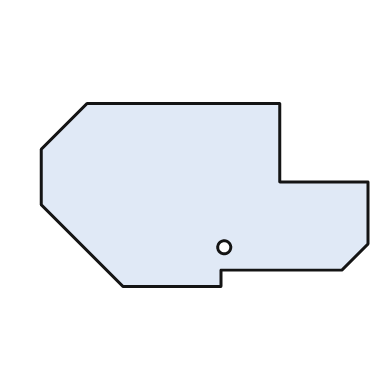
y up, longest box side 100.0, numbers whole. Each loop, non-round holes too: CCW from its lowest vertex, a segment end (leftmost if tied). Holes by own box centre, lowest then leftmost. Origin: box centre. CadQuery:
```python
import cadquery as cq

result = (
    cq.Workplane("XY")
    .moveTo(-25.0, -28.0)
    .lineTo(5.0, -28.0)
    .lineTo(5.0, -23.0)
    .lineTo(42.0, -23.0)
    .lineTo(50.0, -15.0)
    .lineTo(50.0, 4.0)
    .lineTo(23.0, 4.0)
    .lineTo(23.0, 28.0)
    .lineTo(-36.0, 28.0)
    .lineTo(-50.0, 14.0)
    .lineTo(-50.0, -3.0)
    .close()
    .moveTo(6.0, -16.0)
    .circle(2.0)
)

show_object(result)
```